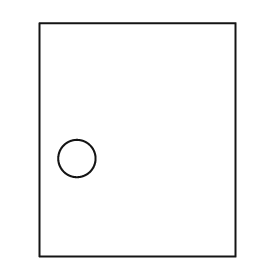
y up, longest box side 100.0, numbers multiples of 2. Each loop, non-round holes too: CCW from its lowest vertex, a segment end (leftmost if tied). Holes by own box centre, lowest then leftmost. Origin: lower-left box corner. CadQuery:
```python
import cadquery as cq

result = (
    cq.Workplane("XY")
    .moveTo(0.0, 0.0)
    .lineTo(84.0, 0.0)
    .lineTo(84.0, 100.0)
    .lineTo(0.0, 100.0)
    .close()
    .moveTo(16.0, 42.0)
    .circle(8.0)
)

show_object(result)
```